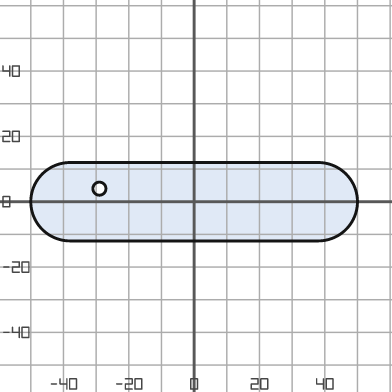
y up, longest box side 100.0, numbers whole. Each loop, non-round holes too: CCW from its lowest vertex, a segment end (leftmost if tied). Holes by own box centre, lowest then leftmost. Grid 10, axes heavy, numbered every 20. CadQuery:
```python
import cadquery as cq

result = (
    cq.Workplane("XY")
    .moveTo(-38.0, -12.0)
    .lineTo(38.0, -12.0)
    .threePointArc((50.0, 0.0), (38.0, 12.0))
    .lineTo(-38.0, 12.0)
    .threePointArc((-50.0, 0.0), (-38.0, -12.0))
    .close()
    .moveTo(-29.0, 4.0)
    .circle(2.0)
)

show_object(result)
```